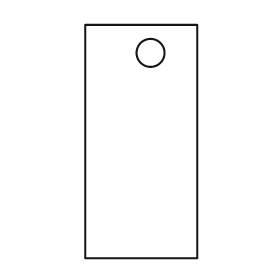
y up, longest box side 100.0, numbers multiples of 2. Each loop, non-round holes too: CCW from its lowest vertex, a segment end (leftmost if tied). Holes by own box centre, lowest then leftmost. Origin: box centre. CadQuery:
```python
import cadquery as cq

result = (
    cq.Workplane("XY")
    .moveTo(-24.0, -50.0)
    .lineTo(24.0, -50.0)
    .lineTo(24.0, 50.0)
    .lineTo(-24.0, 50.0)
    .close()
    .moveTo(4.0, 38.0)
    .circle(6.0)
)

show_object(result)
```